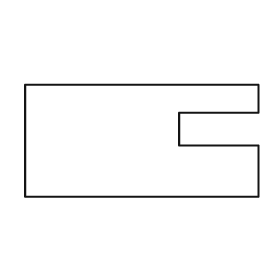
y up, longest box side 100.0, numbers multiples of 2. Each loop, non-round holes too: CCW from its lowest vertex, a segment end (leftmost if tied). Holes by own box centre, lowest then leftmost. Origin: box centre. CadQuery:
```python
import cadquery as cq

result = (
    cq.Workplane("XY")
    .moveTo(-50.0, -24.0)
    .lineTo(50.0, -24.0)
    .lineTo(50.0, -2.0)
    .lineTo(16.0, -2.0)
    .lineTo(16.0, 12.0)
    .lineTo(50.0, 12.0)
    .lineTo(50.0, 24.0)
    .lineTo(-50.0, 24.0)
    .close()
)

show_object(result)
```